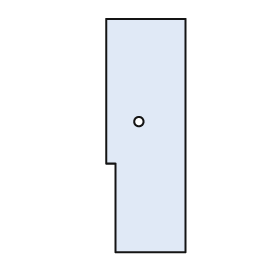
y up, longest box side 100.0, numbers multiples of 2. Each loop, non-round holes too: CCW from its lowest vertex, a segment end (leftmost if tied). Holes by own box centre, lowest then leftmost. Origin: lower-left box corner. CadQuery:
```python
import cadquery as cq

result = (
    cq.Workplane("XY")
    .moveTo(4.0, 0.0)
    .lineTo(34.0, 0.0)
    .lineTo(34.0, 100.0)
    .lineTo(0.0, 100.0)
    .lineTo(0.0, 38.0)
    .lineTo(4.0, 38.0)
    .close()
    .moveTo(14.0, 56.0)
    .circle(2.0)
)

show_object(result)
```